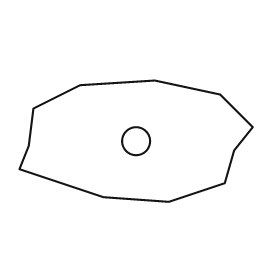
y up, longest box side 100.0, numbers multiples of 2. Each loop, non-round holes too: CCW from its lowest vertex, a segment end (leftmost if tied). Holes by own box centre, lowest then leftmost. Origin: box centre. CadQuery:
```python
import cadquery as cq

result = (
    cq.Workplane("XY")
    .moveTo(14.0, -26.0)
    .lineTo(38.0, -18.0)
    .lineTo(42.0, -4.0)
    .lineTo(50.0, 6.0)
    .lineTo(36.0, 20.0)
    .lineTo(8.0, 26.0)
    .lineTo(-24.0, 24.0)
    .lineTo(-44.0, 14.0)
    .lineTo(-46.0, -2.0)
    .lineTo(-50.0, -12.0)
    .lineTo(-14.0, -24.0)
    .close()
    .moveTo(0.0, 0.0)
    .circle(6.0)
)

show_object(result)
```